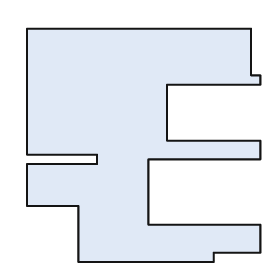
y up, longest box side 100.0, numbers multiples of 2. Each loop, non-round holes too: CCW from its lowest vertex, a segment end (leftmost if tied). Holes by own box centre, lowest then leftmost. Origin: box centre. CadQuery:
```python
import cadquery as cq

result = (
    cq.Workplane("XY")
    .moveTo(-28.0, -50.0)
    .lineTo(30.0, -50.0)
    .lineTo(30.0, -46.0)
    .lineTo(50.0, -46.0)
    .lineTo(50.0, -34.0)
    .lineTo(2.0, -34.0)
    .lineTo(2.0, -6.0)
    .lineTo(50.0, -6.0)
    .lineTo(50.0, 2.0)
    .lineTo(10.0, 2.0)
    .lineTo(10.0, 26.0)
    .lineTo(50.0, 26.0)
    .lineTo(50.0, 30.0)
    .lineTo(46.0, 30.0)
    .lineTo(46.0, 50.0)
    .lineTo(-50.0, 50.0)
    .lineTo(-50.0, -4.0)
    .lineTo(-20.0, -4.0)
    .lineTo(-20.0, -8.0)
    .lineTo(-50.0, -8.0)
    .lineTo(-50.0, -26.0)
    .lineTo(-28.0, -26.0)
    .close()
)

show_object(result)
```